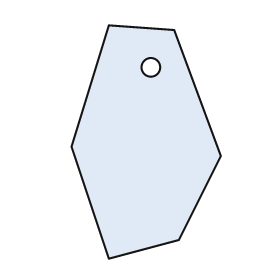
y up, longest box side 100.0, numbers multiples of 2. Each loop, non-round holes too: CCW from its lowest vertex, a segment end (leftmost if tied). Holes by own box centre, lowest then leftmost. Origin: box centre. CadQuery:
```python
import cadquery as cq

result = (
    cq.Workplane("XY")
    .moveTo(-16.0, -50.0)
    .lineTo(14.0, -42.0)
    .lineTo(32.0, -6.0)
    .lineTo(12.0, 48.0)
    .lineTo(-16.0, 50.0)
    .lineTo(-32.0, -2.0)
    .close()
    .moveTo(2.0, 32.0)
    .circle(4.0)
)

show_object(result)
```